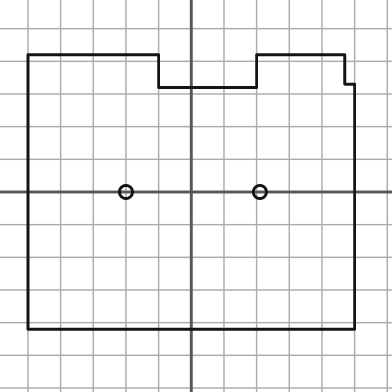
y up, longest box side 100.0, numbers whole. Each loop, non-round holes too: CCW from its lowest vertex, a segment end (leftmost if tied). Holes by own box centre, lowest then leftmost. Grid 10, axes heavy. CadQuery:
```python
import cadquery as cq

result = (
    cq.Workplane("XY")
    .moveTo(-50.0, -42.0)
    .lineTo(50.0, -42.0)
    .lineTo(50.0, 33.0)
    .lineTo(47.0, 33.0)
    .lineTo(47.0, 42.0)
    .lineTo(20.0, 42.0)
    .lineTo(20.0, 32.0)
    .lineTo(-10.0, 32.0)
    .lineTo(-10.0, 42.0)
    .lineTo(-50.0, 42.0)
    .close()
    .moveTo(-20.0, 0.0)
    .circle(2.0)
    .moveTo(21.0, 0.0)
    .circle(2.0)
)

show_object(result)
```